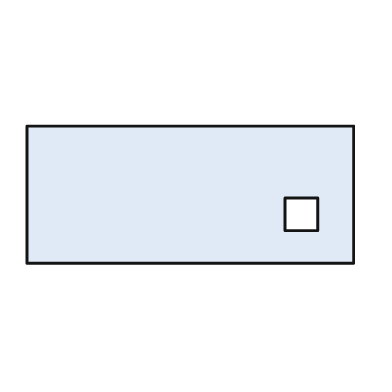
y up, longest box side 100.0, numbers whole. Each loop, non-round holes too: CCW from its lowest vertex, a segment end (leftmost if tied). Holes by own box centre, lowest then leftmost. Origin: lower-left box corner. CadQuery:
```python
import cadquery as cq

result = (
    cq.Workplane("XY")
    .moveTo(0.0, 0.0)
    .lineTo(100.0, 0.0)
    .lineTo(100.0, 42.0)
    .lineTo(0.0, 42.0)
    .close()
    .moveTo(79.0, 10.0)
    .lineTo(89.0, 10.0)
    .lineTo(89.0, 20.0)
    .lineTo(79.0, 20.0)
    .close()
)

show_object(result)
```